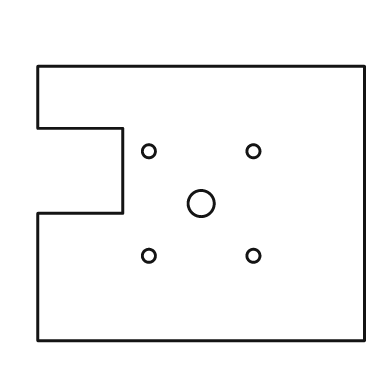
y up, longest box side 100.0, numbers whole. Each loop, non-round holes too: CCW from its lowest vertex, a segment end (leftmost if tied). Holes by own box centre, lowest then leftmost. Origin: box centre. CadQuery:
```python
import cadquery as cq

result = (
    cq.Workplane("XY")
    .moveTo(-50.0, -42.0)
    .lineTo(50.0, -42.0)
    .lineTo(50.0, 42.0)
    .lineTo(-50.0, 42.0)
    .lineTo(-50.0, 23.0)
    .lineTo(-24.0, 23.0)
    .lineTo(-24.0, -3.0)
    .lineTo(-50.0, -3.0)
    .close()
    .moveTo(-16.0, -16.0)
    .circle(2.0)
    .moveTo(16.0, -16.0)
    .circle(2.0)
    .moveTo(0.0, 0.0)
    .circle(4.0)
    .moveTo(-16.0, 16.0)
    .circle(2.0)
    .moveTo(16.0, 16.0)
    .circle(2.0)
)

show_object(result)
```